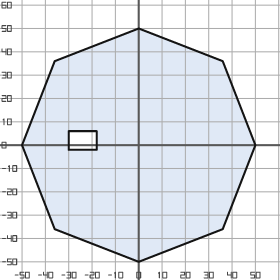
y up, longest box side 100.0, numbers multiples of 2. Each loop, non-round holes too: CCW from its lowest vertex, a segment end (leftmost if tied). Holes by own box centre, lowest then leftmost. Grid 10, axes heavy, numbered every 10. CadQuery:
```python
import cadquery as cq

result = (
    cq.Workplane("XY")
    .moveTo(0.0, -50.0)
    .lineTo(36.0, -36.0)
    .lineTo(50.0, 0.0)
    .lineTo(36.0, 36.0)
    .lineTo(0.0, 50.0)
    .lineTo(-36.0, 36.0)
    .lineTo(-50.0, 0.0)
    .lineTo(-36.0, -36.0)
    .close()
    .moveTo(-30.0, -2.0)
    .lineTo(-18.0, -2.0)
    .lineTo(-18.0, 6.0)
    .lineTo(-30.0, 6.0)
    .close()
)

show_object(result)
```